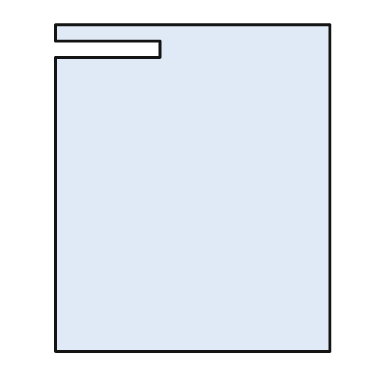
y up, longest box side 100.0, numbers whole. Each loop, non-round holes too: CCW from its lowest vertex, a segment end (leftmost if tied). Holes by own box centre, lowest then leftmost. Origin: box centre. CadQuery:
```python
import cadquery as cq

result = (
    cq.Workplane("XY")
    .moveTo(-42.0, -50.0)
    .lineTo(42.0, -50.0)
    .lineTo(42.0, 50.0)
    .lineTo(-42.0, 50.0)
    .lineTo(-42.0, 45.0)
    .lineTo(-10.0, 45.0)
    .lineTo(-10.0, 40.0)
    .lineTo(-42.0, 40.0)
    .close()
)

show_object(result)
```